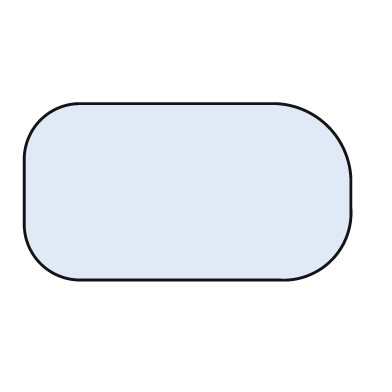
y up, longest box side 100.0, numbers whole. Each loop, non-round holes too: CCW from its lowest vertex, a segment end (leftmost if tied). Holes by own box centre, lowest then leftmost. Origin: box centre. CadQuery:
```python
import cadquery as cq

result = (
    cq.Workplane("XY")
    .moveTo(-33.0, -27.0)
    .lineTo(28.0, -27.0)
    .threePointArc((44.0, -21.0), (50.0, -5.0))
    .lineTo(50.0, 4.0)
    .threePointArc((43.0, 20.0), (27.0, 27.0))
    .lineTo(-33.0, 27.0)
    .threePointArc((-45.0, 22.0), (-50.0, 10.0))
    .lineTo(-50.0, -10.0)
    .threePointArc((-45.0, -22.0), (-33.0, -27.0))
    .close()
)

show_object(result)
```